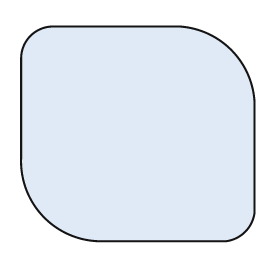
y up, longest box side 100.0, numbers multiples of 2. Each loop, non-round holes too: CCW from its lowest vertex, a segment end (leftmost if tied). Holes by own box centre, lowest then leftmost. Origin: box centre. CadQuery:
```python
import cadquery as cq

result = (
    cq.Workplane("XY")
    .moveTo(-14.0, -46.0)
    .lineTo(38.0, -46.0)
    .threePointArc((46.0, -42.0), (50.0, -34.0))
    .lineTo(50.0, 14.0)
    .threePointArc((40.0, 36.0), (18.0, 46.0))
    .lineTo(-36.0, 46.0)
    .threePointArc((-46.0, 42.0), (-50.0, 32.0))
    .lineTo(-50.0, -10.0)
    .threePointArc((-40.0, -36.0), (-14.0, -46.0))
    .close()
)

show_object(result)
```